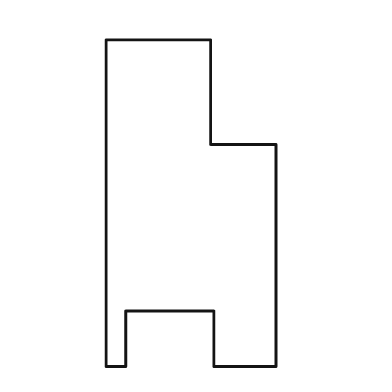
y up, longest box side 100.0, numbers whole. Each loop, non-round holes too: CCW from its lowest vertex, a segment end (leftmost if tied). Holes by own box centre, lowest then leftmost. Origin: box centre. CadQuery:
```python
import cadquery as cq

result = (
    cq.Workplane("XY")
    .moveTo(-26.0, -50.0)
    .lineTo(-20.0, -50.0)
    .lineTo(-20.0, -33.0)
    .lineTo(7.0, -33.0)
    .lineTo(7.0, -50.0)
    .lineTo(26.0, -50.0)
    .lineTo(26.0, 18.0)
    .lineTo(6.0, 18.0)
    .lineTo(6.0, 50.0)
    .lineTo(-26.0, 50.0)
    .close()
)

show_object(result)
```